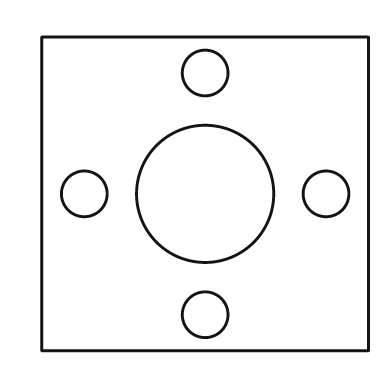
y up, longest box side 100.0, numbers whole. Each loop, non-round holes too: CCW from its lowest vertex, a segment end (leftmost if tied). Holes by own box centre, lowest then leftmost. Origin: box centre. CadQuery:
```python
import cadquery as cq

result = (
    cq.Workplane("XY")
    .moveTo(-50.0, -48.0)
    .lineTo(50.0, -48.0)
    .lineTo(50.0, 48.0)
    .lineTo(-50.0, 48.0)
    .close()
    .moveTo(0.0, -37.0)
    .circle(7.0)
    .moveTo(-37.0, 0.0)
    .circle(7.0)
    .moveTo(0.0, 0.0)
    .circle(21.0)
    .moveTo(37.0, 0.0)
    .circle(7.0)
    .moveTo(0.0, 37.0)
    .circle(7.0)
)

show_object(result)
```